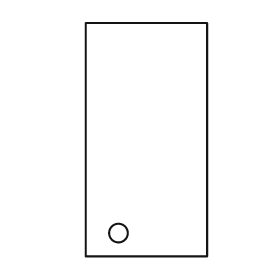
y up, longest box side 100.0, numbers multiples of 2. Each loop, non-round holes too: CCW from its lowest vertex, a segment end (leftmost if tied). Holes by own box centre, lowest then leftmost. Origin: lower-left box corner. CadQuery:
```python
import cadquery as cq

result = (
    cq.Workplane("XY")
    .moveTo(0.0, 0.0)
    .lineTo(52.0, 0.0)
    .lineTo(52.0, 100.0)
    .lineTo(0.0, 100.0)
    .close()
    .moveTo(14.0, 10.0)
    .circle(4.0)
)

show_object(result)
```